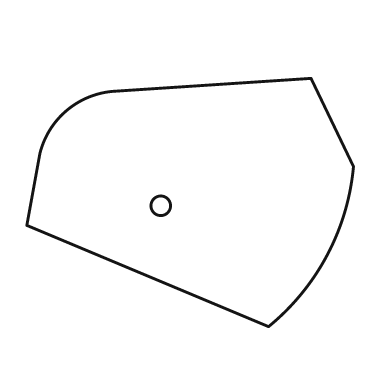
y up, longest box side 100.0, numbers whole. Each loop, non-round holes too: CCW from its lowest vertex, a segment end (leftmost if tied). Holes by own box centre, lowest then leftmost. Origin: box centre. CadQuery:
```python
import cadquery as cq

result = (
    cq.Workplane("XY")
    .moveTo(24.0, -38.0)
    .threePointArc((42.0, -16.0), (50.0, 11.0))
    .lineTo(37.0, 38.0)
    .lineTo(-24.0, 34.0)
    .threePointArc((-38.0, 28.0), (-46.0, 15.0))
    .lineTo(-50.0, -7.0)
    .close()
    .moveTo(-9.0, -1.0)
    .circle(3.0)
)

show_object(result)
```